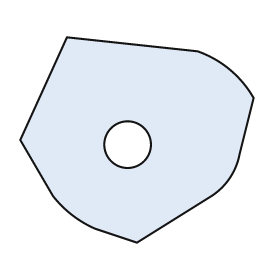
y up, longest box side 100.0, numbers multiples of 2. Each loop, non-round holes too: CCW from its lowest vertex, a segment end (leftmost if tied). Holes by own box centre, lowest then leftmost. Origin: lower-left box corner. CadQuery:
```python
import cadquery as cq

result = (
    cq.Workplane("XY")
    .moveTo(50.0, 0.0)
    .lineTo(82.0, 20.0)
    .threePointArc((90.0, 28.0), (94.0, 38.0))
    .lineTo(100.0, 62.0)
    .threePointArc((90.0, 74.0), (76.0, 82.0))
    .lineTo(20.0, 88.0)
    .lineTo(0.0, 44.0)
    .lineTo(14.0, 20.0)
    .threePointArc((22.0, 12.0), (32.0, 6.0))
    .close()
    .moveTo(46.0, 42.0)
    .circle(10.0)
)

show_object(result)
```